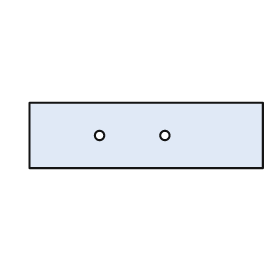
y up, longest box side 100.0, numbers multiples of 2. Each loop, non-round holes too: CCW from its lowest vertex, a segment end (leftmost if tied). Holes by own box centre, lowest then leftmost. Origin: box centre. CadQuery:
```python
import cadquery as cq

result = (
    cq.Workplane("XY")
    .moveTo(-50.0, -14.0)
    .lineTo(50.0, -14.0)
    .lineTo(50.0, 14.0)
    .lineTo(-50.0, 14.0)
    .close()
    .moveTo(-20.0, 0.0)
    .circle(2.0)
    .moveTo(8.0, 0.0)
    .circle(2.0)
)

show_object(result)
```